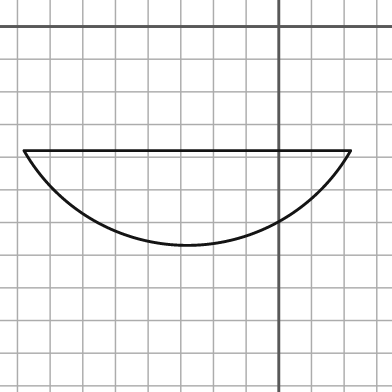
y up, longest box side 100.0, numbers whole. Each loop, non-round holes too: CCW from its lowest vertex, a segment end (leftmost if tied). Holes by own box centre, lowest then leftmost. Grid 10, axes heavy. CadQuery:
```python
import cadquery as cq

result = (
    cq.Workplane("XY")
    .moveTo(-78.0, -38.0)
    .threePointArc((-28.0, -67.0), (22.0, -38.0))
    .close()
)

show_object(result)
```